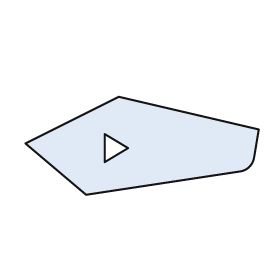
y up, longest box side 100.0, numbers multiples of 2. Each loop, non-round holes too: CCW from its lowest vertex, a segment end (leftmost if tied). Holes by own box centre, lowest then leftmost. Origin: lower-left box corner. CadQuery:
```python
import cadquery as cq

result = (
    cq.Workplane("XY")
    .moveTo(26.0, 0.0)
    .lineTo(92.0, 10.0)
    .threePointArc((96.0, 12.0), (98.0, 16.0))
    .lineTo(100.0, 28.0)
    .lineTo(40.0, 42.0)
    .lineTo(0.0, 22.0)
    .close()
    .moveTo(34.0, 14.0)
    .lineTo(44.0, 20.0)
    .lineTo(34.0, 26.0)
    .close()
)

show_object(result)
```